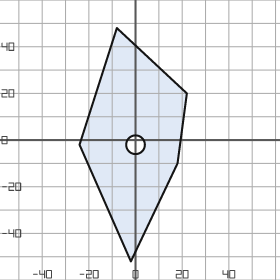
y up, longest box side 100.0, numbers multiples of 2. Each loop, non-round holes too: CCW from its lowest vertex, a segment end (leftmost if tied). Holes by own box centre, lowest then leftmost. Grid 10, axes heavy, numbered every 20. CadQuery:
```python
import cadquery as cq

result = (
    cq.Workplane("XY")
    .moveTo(-2.0, -52.0)
    .lineTo(18.0, -10.0)
    .lineTo(22.0, 20.0)
    .lineTo(-8.0, 48.0)
    .lineTo(-24.0, -2.0)
    .close()
    .moveTo(0.0, -2.0)
    .circle(4.0)
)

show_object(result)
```